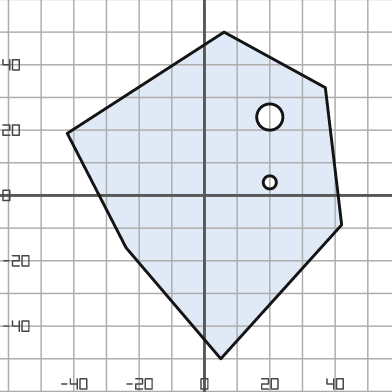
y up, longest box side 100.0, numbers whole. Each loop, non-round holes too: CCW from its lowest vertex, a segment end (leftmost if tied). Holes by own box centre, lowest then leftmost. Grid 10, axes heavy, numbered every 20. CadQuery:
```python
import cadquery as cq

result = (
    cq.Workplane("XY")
    .moveTo(5.0, -50.0)
    .lineTo(42.0, -9.0)
    .lineTo(37.0, 33.0)
    .lineTo(6.0, 50.0)
    .lineTo(-42.0, 19.0)
    .lineTo(-24.0, -16.0)
    .close()
    .moveTo(20.0, 4.0)
    .circle(2.0)
    .moveTo(20.0, 24.0)
    .circle(4.0)
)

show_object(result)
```